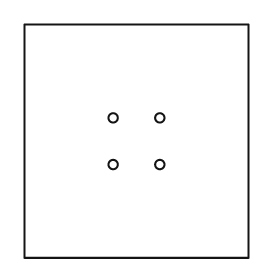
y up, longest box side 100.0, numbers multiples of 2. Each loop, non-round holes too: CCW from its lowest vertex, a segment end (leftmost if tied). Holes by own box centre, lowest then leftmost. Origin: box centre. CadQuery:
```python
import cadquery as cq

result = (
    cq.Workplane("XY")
    .moveTo(-48.0, -50.0)
    .lineTo(48.0, -50.0)
    .lineTo(48.0, 50.0)
    .lineTo(-48.0, 50.0)
    .close()
    .moveTo(-10.0, -10.0)
    .circle(2.0)
    .moveTo(10.0, -10.0)
    .circle(2.0)
    .moveTo(-10.0, 10.0)
    .circle(2.0)
    .moveTo(10.0, 10.0)
    .circle(2.0)
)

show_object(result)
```